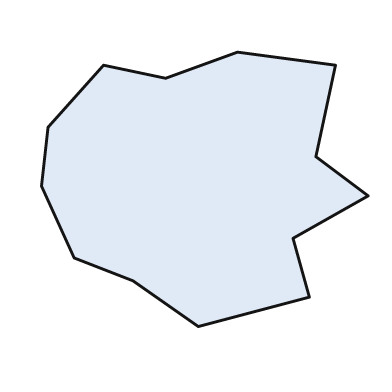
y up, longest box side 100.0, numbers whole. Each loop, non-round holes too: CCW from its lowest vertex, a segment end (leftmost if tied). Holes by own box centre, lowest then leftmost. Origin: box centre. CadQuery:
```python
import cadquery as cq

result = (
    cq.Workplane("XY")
    .moveTo(-2.0, -42.0)
    .lineTo(32.0, -33.0)
    .lineTo(27.0, -15.0)
    .lineTo(50.0, -2.0)
    .lineTo(34.0, 10.0)
    .lineTo(40.0, 38.0)
    .lineTo(10.0, 42.0)
    .lineTo(-12.0, 34.0)
    .lineTo(-31.0, 38.0)
    .lineTo(-48.0, 19.0)
    .lineTo(-50.0, 1.0)
    .lineTo(-40.0, -21.0)
    .lineTo(-22.0, -28.0)
    .close()
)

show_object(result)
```